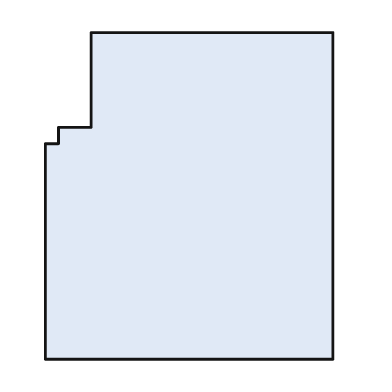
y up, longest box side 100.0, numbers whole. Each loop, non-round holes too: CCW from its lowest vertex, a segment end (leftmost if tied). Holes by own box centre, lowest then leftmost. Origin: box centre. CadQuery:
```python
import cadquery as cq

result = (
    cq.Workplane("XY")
    .moveTo(-44.0, -50.0)
    .lineTo(44.0, -50.0)
    .lineTo(44.0, 50.0)
    .lineTo(-30.0, 50.0)
    .lineTo(-30.0, 21.0)
    .lineTo(-40.0, 21.0)
    .lineTo(-40.0, 16.0)
    .lineTo(-44.0, 16.0)
    .close()
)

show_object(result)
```